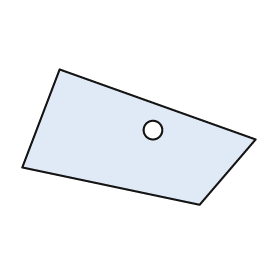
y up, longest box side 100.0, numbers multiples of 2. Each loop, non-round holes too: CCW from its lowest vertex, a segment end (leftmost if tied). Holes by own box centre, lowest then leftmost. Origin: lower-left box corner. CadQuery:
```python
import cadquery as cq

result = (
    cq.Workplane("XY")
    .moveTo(76.0, 0.0)
    .lineTo(100.0, 28.0)
    .lineTo(16.0, 58.0)
    .lineTo(0.0, 16.0)
    .close()
    .moveTo(56.0, 32.0)
    .circle(4.0)
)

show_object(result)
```